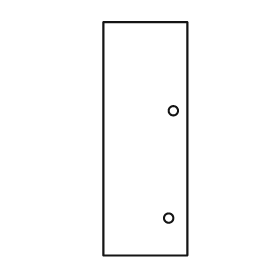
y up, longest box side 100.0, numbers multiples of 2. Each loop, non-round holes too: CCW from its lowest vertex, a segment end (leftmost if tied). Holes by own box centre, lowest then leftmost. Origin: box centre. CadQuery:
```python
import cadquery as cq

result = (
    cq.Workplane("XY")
    .moveTo(-18.0, -50.0)
    .lineTo(18.0, -50.0)
    .lineTo(18.0, 50.0)
    .lineTo(-18.0, 50.0)
    .close()
    .moveTo(10.0, -34.0)
    .circle(2.0)
    .moveTo(12.0, 12.0)
    .circle(2.0)
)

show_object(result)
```